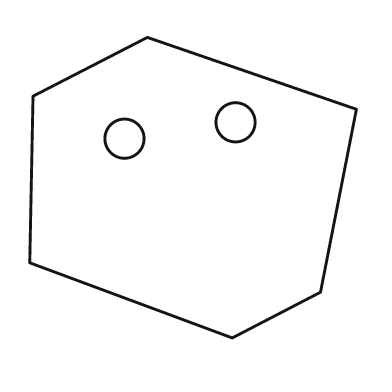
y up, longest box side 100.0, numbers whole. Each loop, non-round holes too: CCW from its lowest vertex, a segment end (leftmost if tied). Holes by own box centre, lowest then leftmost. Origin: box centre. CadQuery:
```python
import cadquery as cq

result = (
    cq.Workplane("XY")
    .moveTo(12.0, -46.0)
    .lineTo(39.0, -32.0)
    .lineTo(50.0, 24.0)
    .lineTo(-14.0, 46.0)
    .lineTo(-49.0, 28.0)
    .lineTo(-50.0, -23.0)
    .close()
    .moveTo(-21.0, 15.0)
    .circle(6.0)
    .moveTo(13.0, 20.0)
    .circle(6.0)
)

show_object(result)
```